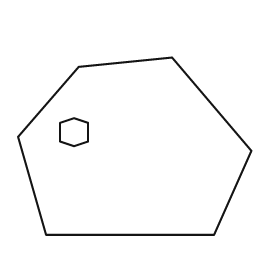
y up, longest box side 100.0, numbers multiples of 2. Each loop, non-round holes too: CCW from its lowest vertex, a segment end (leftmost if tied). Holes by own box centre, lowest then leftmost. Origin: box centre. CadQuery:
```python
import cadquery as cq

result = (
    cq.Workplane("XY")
    .moveTo(-38.0, -38.0)
    .lineTo(34.0, -38.0)
    .lineTo(50.0, -2.0)
    .lineTo(16.0, 38.0)
    .lineTo(-24.0, 34.0)
    .lineTo(-50.0, 4.0)
    .close()
    .moveTo(-26.0, 0.0)
    .lineTo(-20.0, 2.0)
    .lineTo(-20.0, 10.0)
    .lineTo(-26.0, 12.0)
    .lineTo(-32.0, 10.0)
    .lineTo(-32.0, 2.0)
    .close()
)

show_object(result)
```